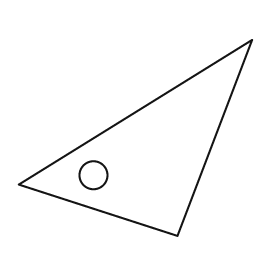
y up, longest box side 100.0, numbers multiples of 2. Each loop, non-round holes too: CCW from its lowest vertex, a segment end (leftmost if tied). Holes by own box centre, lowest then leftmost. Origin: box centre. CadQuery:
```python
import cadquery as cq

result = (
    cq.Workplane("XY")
    .moveTo(18.0, -42.0)
    .lineTo(50.0, 42.0)
    .lineTo(-50.0, -20.0)
    .close()
    .moveTo(-18.0, -16.0)
    .circle(6.0)
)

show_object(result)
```